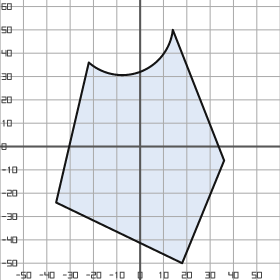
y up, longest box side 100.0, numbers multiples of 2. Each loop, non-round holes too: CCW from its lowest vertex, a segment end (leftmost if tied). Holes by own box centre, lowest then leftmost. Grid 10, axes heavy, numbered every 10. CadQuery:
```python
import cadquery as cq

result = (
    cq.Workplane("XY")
    .moveTo(18.0, -50.0)
    .lineTo(36.0, -6.0)
    .lineTo(14.0, 50.0)
    .threePointArc((0.0, 32.0), (-22.0, 36.0))
    .lineTo(-36.0, -24.0)
    .close()
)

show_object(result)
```